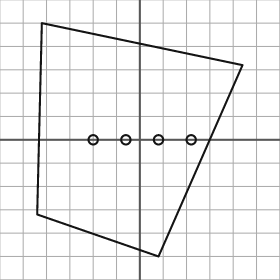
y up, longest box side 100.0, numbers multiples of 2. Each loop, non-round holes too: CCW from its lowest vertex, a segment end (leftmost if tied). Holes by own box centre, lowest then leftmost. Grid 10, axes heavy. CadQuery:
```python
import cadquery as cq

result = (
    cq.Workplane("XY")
    .moveTo(8.0, -50.0)
    .lineTo(44.0, 32.0)
    .lineTo(-42.0, 50.0)
    .lineTo(-44.0, -32.0)
    .close()
    .moveTo(-20.0, 0.0)
    .circle(2.0)
    .moveTo(-6.0, 0.0)
    .circle(2.0)
    .moveTo(8.0, 0.0)
    .circle(2.0)
    .moveTo(22.0, 0.0)
    .circle(2.0)
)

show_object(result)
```